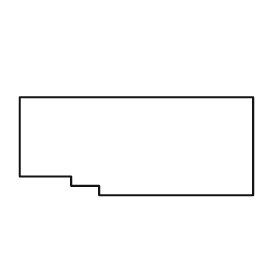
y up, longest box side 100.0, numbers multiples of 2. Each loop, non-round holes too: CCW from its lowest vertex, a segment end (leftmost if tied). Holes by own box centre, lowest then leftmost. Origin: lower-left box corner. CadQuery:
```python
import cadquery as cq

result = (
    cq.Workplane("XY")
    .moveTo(34.0, 0.0)
    .lineTo(100.0, 0.0)
    .lineTo(100.0, 42.0)
    .lineTo(0.0, 42.0)
    .lineTo(0.0, 8.0)
    .lineTo(22.0, 8.0)
    .lineTo(22.0, 4.0)
    .lineTo(34.0, 4.0)
    .close()
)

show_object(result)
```